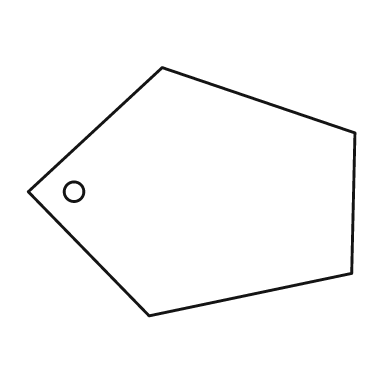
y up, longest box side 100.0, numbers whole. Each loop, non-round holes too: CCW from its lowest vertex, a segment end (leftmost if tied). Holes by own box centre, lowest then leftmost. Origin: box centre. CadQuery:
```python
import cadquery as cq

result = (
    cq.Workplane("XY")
    .moveTo(-13.0, -38.0)
    .lineTo(49.0, -25.0)
    .lineTo(50.0, 18.0)
    .lineTo(-9.0, 38.0)
    .lineTo(-50.0, 0.0)
    .close()
    .moveTo(-36.0, 0.0)
    .circle(3.0)
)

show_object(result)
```